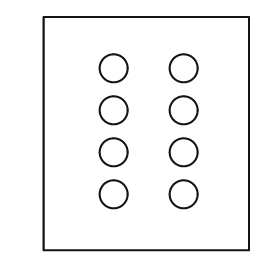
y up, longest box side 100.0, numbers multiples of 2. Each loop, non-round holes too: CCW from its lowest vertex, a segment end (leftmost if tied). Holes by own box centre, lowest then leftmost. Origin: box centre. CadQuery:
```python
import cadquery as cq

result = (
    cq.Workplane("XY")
    .moveTo(-44.0, -50.0)
    .lineTo(44.0, -50.0)
    .lineTo(44.0, 50.0)
    .lineTo(-44.0, 50.0)
    .close()
    .moveTo(-14.0, -26.0)
    .circle(6.0)
    .moveTo(16.0, -26.0)
    .circle(6.0)
    .moveTo(-14.0, -8.0)
    .circle(6.0)
    .moveTo(16.0, -8.0)
    .circle(6.0)
    .moveTo(-14.0, 10.0)
    .circle(6.0)
    .moveTo(16.0, 10.0)
    .circle(6.0)
    .moveTo(-14.0, 28.0)
    .circle(6.0)
    .moveTo(16.0, 28.0)
    .circle(6.0)
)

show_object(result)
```